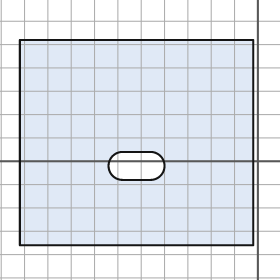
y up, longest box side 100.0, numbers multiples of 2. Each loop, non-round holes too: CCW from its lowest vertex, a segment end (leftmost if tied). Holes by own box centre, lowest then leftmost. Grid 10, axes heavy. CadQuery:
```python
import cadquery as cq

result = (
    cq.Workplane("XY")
    .moveTo(-102.0, -36.0)
    .lineTo(-2.0, -36.0)
    .lineTo(-2.0, 52.0)
    .lineTo(-102.0, 52.0)
    .close()
    .moveTo(-58.0, -8.0)
    .lineTo(-46.0, -8.0)
    .threePointArc((-40.0, -2.0), (-46.0, 4.0))
    .lineTo(-58.0, 4.0)
    .threePointArc((-64.0, -2.0), (-58.0, -8.0))
    .close()
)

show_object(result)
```